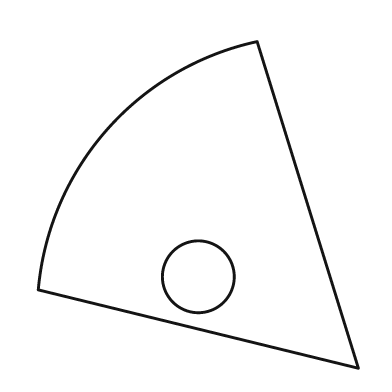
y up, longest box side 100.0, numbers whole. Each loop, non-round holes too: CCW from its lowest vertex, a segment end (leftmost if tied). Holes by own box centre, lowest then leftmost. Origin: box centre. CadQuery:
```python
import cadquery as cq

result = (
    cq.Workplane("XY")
    .moveTo(49.0, -50.0)
    .lineTo(18.0, 50.0)
    .threePointArc((-28.0, 23.0), (-49.0, -26.0))
    .close()
    .moveTo(0.0, -22.0)
    .circle(11.0)
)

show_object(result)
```